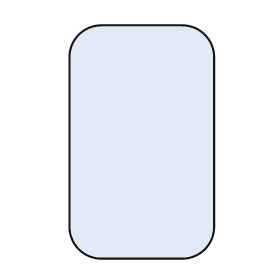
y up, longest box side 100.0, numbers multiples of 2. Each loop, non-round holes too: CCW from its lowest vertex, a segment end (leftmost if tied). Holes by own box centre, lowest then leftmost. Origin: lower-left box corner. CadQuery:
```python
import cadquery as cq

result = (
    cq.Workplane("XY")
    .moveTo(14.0, 0.0)
    .lineTo(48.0, 0.0)
    .threePointArc((58.0, 4.0), (62.0, 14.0))
    .lineTo(62.0, 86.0)
    .threePointArc((58.0, 96.0), (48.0, 100.0))
    .lineTo(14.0, 100.0)
    .threePointArc((4.0, 96.0), (0.0, 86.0))
    .lineTo(0.0, 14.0)
    .threePointArc((4.0, 4.0), (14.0, 0.0))
    .close()
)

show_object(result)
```